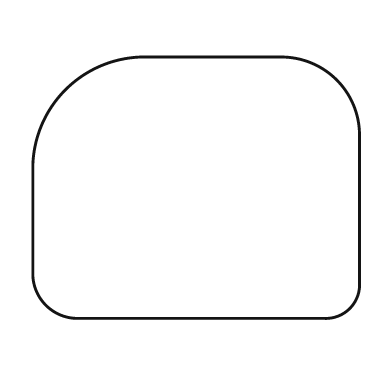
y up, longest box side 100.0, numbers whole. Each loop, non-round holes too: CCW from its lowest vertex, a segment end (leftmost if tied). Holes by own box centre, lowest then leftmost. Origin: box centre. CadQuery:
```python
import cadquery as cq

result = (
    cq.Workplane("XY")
    .moveTo(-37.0, -40.0)
    .lineTo(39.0, -40.0)
    .threePointArc((47.0, -37.0), (50.0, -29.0))
    .lineTo(50.0, 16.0)
    .threePointArc((43.0, 33.0), (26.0, 40.0))
    .lineTo(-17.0, 40.0)
    .threePointArc((-40.0, 30.0), (-50.0, 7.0))
    .lineTo(-50.0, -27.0)
    .threePointArc((-46.0, -36.0), (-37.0, -40.0))
    .close()
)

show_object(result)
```